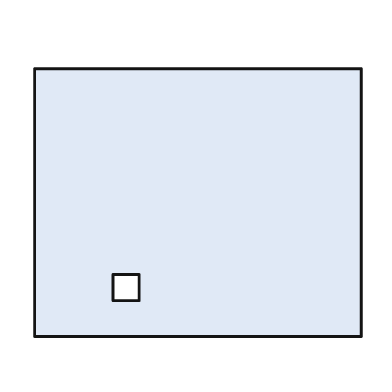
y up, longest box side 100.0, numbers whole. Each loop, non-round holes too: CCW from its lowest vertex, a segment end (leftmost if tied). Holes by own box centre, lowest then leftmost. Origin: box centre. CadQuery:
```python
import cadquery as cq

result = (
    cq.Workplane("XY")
    .moveTo(-50.0, -41.0)
    .lineTo(50.0, -41.0)
    .lineTo(50.0, 41.0)
    .lineTo(-50.0, 41.0)
    .close()
    .moveTo(-26.0, -30.0)
    .lineTo(-18.0, -30.0)
    .lineTo(-18.0, -22.0)
    .lineTo(-26.0, -22.0)
    .close()
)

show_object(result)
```